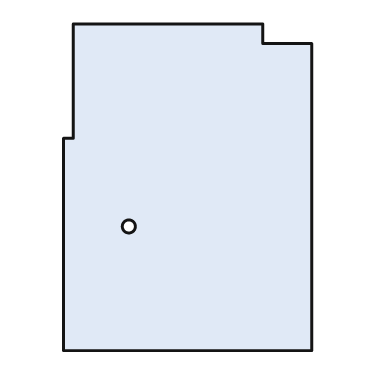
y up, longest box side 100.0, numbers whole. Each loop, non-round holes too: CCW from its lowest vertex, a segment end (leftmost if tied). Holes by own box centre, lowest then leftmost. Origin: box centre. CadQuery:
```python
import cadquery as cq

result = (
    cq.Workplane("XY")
    .moveTo(-38.0, -50.0)
    .lineTo(38.0, -50.0)
    .lineTo(38.0, 44.0)
    .lineTo(23.0, 44.0)
    .lineTo(23.0, 50.0)
    .lineTo(-35.0, 50.0)
    .lineTo(-35.0, 15.0)
    .lineTo(-38.0, 15.0)
    .close()
    .moveTo(-18.0, -12.0)
    .circle(2.0)
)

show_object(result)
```